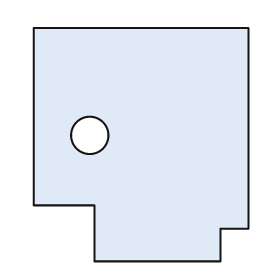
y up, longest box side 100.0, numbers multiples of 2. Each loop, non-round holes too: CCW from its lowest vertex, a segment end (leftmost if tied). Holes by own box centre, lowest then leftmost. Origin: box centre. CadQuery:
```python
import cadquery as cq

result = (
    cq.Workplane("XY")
    .moveTo(-20.0, -50.0)
    .lineTo(34.0, -50.0)
    .lineTo(34.0, -36.0)
    .lineTo(46.0, -36.0)
    .lineTo(46.0, 50.0)
    .lineTo(-46.0, 50.0)
    .lineTo(-46.0, -26.0)
    .lineTo(-20.0, -26.0)
    .close()
    .moveTo(-22.0, 4.0)
    .circle(8.0)
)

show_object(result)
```